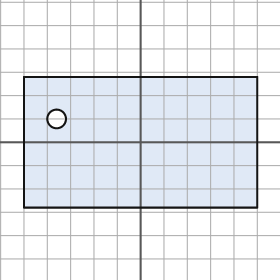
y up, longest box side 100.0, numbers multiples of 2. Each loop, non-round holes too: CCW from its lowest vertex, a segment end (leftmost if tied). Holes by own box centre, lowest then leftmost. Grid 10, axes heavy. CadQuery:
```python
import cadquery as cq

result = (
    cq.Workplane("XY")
    .moveTo(-50.0, -28.0)
    .lineTo(50.0, -28.0)
    .lineTo(50.0, 28.0)
    .lineTo(-50.0, 28.0)
    .close()
    .moveTo(-36.0, 10.0)
    .circle(4.0)
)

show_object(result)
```